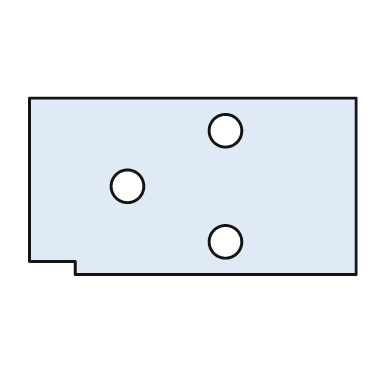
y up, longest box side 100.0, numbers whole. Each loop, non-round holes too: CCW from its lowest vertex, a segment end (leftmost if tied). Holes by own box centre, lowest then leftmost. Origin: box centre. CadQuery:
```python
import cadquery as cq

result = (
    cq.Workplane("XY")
    .moveTo(-36.0, -27.0)
    .lineTo(50.0, -27.0)
    .lineTo(50.0, 27.0)
    .lineTo(-50.0, 27.0)
    .lineTo(-50.0, -23.0)
    .lineTo(-36.0, -23.0)
    .close()
    .moveTo(10.0, -17.0)
    .circle(5.0)
    .moveTo(-20.0, 0.0)
    .circle(5.0)
    .moveTo(10.0, 17.0)
    .circle(5.0)
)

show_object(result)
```